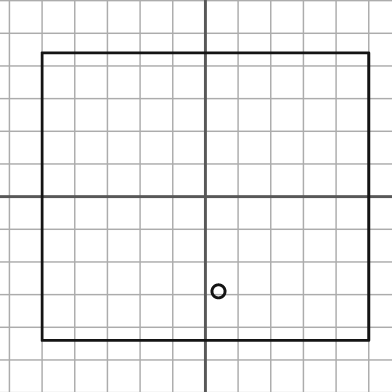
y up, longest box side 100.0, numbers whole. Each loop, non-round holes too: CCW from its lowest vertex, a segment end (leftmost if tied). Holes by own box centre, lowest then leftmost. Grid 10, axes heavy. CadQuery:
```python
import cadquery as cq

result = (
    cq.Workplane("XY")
    .moveTo(-50.0, -44.0)
    .lineTo(50.0, -44.0)
    .lineTo(50.0, 44.0)
    .lineTo(-50.0, 44.0)
    .close()
    .moveTo(4.0, -29.0)
    .circle(2.0)
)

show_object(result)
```